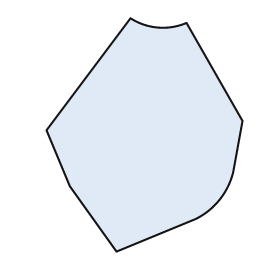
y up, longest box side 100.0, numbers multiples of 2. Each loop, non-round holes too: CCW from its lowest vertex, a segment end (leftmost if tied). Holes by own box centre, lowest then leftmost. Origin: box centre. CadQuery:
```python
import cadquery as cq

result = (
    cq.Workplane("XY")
    .moveTo(-12.0, -50.0)
    .lineTo(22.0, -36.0)
    .threePointArc((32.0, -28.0), (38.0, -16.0))
    .lineTo(42.0, 6.0)
    .lineTo(18.0, 48.0)
    .threePointArc((6.0, 46.0), (-6.0, 50.0))
    .lineTo(-42.0, 2.0)
    .lineTo(-32.0, -22.0)
    .close()
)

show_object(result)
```